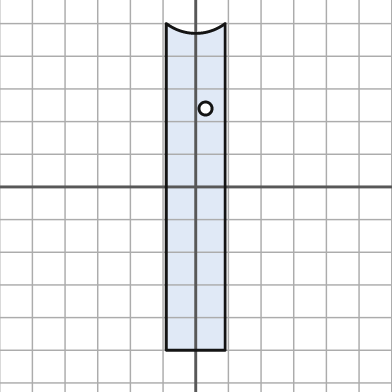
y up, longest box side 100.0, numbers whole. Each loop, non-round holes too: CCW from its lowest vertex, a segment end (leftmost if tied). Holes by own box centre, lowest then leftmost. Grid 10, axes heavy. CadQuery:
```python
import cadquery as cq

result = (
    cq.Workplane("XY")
    .moveTo(-9.0, -50.0)
    .lineTo(9.0, -50.0)
    .lineTo(9.0, 50.0)
    .threePointArc((0.0, 47.0), (-9.0, 50.0))
    .close()
    .moveTo(3.0, 24.0)
    .circle(2.0)
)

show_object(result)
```